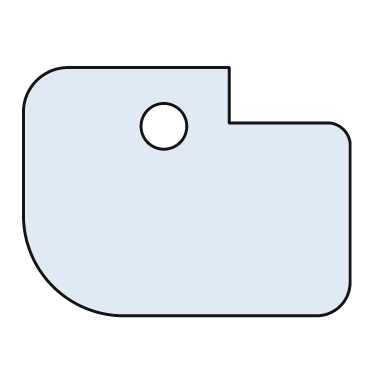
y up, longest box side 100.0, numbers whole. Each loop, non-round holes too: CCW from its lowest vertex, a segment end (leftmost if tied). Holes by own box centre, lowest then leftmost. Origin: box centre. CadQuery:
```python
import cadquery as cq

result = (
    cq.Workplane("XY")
    .moveTo(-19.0, -38.0)
    .lineTo(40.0, -38.0)
    .threePointArc((47.0, -35.0), (50.0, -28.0))
    .lineTo(50.0, 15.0)
    .threePointArc((48.0, 19.0), (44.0, 21.0))
    .lineTo(13.0, 21.0)
    .lineTo(13.0, 38.0)
    .lineTo(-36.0, 38.0)
    .threePointArc((-46.0, 34.0), (-50.0, 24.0))
    .lineTo(-50.0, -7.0)
    .threePointArc((-41.0, -29.0), (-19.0, -38.0))
    .close()
    .moveTo(-7.0, 20.0)
    .circle(7.0)
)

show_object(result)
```